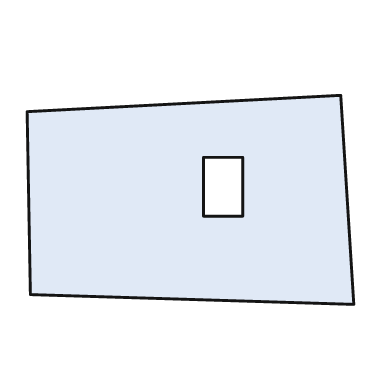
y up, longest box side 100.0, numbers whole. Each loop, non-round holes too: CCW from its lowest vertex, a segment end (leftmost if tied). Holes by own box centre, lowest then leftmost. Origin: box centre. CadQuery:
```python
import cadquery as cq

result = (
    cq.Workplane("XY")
    .moveTo(50.0, -32.0)
    .lineTo(46.0, 32.0)
    .lineTo(-50.0, 27.0)
    .lineTo(-49.0, -29.0)
    .close()
    .moveTo(4.0, -5.0)
    .lineTo(16.0, -5.0)
    .lineTo(16.0, 13.0)
    .lineTo(4.0, 13.0)
    .close()
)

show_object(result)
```